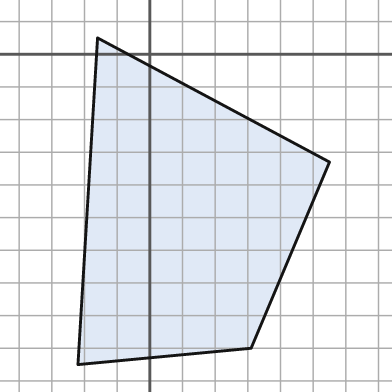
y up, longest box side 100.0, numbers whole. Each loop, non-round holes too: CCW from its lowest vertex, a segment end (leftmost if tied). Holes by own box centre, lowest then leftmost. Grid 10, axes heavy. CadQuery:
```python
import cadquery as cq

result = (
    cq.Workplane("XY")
    .moveTo(-22.0, -95.0)
    .lineTo(31.0, -90.0)
    .lineTo(55.0, -33.0)
    .lineTo(-16.0, 5.0)
    .close()
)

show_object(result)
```